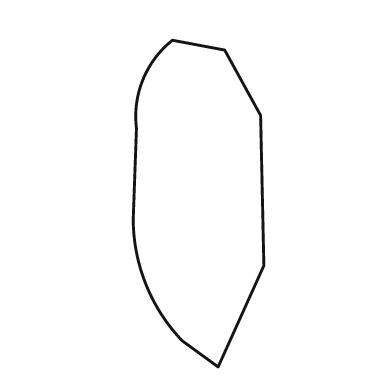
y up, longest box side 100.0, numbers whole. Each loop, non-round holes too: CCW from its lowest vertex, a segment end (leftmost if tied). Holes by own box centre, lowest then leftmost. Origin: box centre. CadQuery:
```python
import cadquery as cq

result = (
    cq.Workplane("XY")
    .moveTo(6.0, -50.0)
    .lineTo(20.0, -19.0)
    .lineTo(19.0, 27.0)
    .lineTo(8.0, 47.0)
    .lineTo(-8.0, 50.0)
    .threePointArc((-17.0, 38.0), (-19.0, 23.0))
    .lineTo(-20.0, -5.0)
    .threePointArc((-16.0, -25.0), (-5.0, -42.0))
    .close()
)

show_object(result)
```